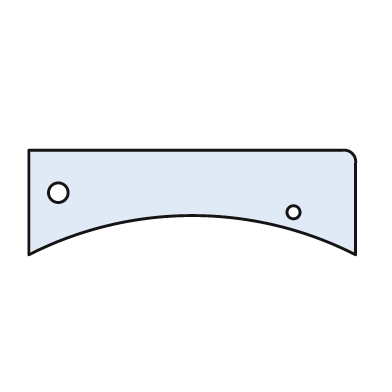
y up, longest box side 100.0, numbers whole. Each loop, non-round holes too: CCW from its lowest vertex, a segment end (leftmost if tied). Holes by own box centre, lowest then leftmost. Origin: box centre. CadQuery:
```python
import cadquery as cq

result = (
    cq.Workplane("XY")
    .moveTo(-50.0, -16.0)
    .threePointArc((0.0, -4.0), (50.0, -16.0))
    .lineTo(50.0, 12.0)
    .threePointArc((49.0, 15.0), (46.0, 16.0))
    .lineTo(-50.0, 16.0)
    .close()
    .moveTo(31.0, -3.0)
    .circle(2.0)
    .moveTo(-41.0, 3.0)
    .circle(3.0)
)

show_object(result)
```